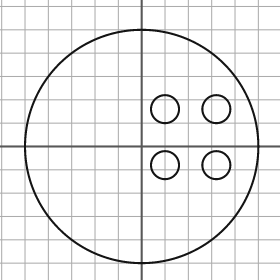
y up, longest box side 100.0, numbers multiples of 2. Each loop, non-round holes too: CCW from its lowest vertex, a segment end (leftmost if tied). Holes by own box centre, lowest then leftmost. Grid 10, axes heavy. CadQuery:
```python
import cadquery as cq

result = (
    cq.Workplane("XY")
    .moveTo(0.0, 0.0)
    .circle(50.0)
    .moveTo(10.0, -8.0)
    .circle(6.0)
    .moveTo(32.0, -8.0)
    .circle(6.0)
    .moveTo(10.0, 16.0)
    .circle(6.0)
    .moveTo(32.0, 16.0)
    .circle(6.0)
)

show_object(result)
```